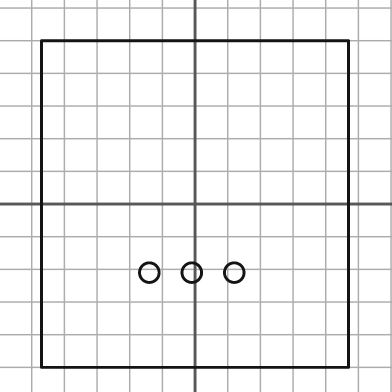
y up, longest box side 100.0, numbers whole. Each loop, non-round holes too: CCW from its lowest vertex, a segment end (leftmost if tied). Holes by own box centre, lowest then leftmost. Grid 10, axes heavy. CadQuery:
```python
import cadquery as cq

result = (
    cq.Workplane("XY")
    .moveTo(-47.0, -50.0)
    .lineTo(47.0, -50.0)
    .lineTo(47.0, 50.0)
    .lineTo(-47.0, 50.0)
    .close()
    .moveTo(-14.0, -21.0)
    .circle(3.0)
    .moveTo(-1.0, -21.0)
    .circle(3.0)
    .moveTo(12.0, -21.0)
    .circle(3.0)
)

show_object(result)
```